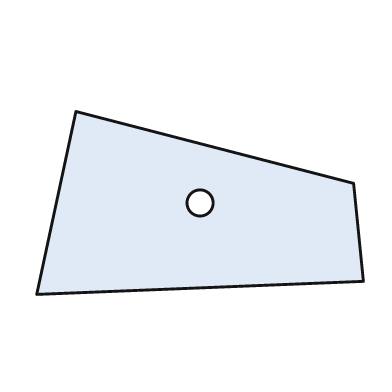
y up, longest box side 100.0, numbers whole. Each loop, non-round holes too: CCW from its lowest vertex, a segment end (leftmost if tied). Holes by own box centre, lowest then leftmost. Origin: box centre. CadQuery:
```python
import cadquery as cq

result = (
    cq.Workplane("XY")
    .moveTo(-50.0, -28.0)
    .lineTo(50.0, -24.0)
    .lineTo(47.0, 6.0)
    .lineTo(-38.0, 28.0)
    .close()
    .moveTo(0.0, 0.0)
    .circle(4.0)
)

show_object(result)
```